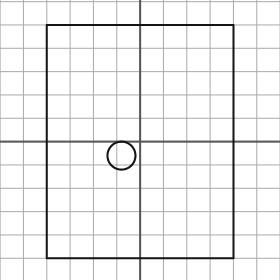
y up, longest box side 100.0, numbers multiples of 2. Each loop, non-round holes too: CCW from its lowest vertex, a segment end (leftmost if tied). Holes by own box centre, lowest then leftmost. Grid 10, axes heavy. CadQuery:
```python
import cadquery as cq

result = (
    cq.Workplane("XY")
    .moveTo(-40.0, -50.0)
    .lineTo(40.0, -50.0)
    .lineTo(40.0, 50.0)
    .lineTo(-40.0, 50.0)
    .close()
    .moveTo(-8.0, -6.0)
    .circle(6.0)
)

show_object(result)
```